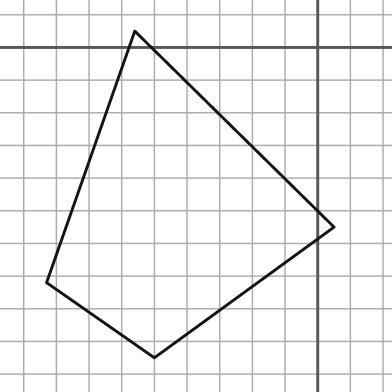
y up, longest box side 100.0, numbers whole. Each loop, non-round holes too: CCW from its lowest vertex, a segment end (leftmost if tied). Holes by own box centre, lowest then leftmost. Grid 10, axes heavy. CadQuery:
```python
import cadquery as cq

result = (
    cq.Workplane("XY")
    .moveTo(-50.0, -95.0)
    .lineTo(5.0, -55.0)
    .lineTo(-56.0, 5.0)
    .lineTo(-83.0, -72.0)
    .close()
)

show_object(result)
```